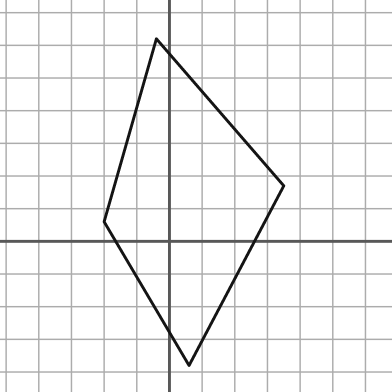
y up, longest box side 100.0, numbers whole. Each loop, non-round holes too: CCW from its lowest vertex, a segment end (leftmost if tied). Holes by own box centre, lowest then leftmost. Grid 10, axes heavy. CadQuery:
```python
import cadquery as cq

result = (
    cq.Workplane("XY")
    .moveTo(6.0, -38.0)
    .lineTo(35.0, 17.0)
    .lineTo(-4.0, 62.0)
    .lineTo(-20.0, 6.0)
    .close()
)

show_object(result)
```